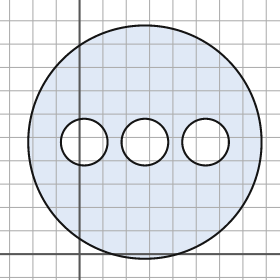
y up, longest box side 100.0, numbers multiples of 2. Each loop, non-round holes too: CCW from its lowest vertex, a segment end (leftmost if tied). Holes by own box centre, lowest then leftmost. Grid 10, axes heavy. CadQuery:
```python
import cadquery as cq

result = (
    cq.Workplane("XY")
    .moveTo(28.0, 48.0)
    .circle(50.0)
    .moveTo(2.0, 48.0)
    .circle(10.0)
    .moveTo(28.0, 48.0)
    .circle(10.0)
    .moveTo(54.0, 48.0)
    .circle(10.0)
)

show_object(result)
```